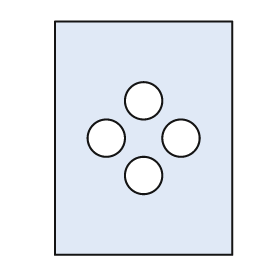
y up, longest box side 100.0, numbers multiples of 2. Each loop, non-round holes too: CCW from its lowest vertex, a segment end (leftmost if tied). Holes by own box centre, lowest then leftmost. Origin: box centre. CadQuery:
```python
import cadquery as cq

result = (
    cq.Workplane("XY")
    .moveTo(-38.0, -50.0)
    .lineTo(38.0, -50.0)
    .lineTo(38.0, 50.0)
    .lineTo(-38.0, 50.0)
    .close()
    .moveTo(0.0, -16.0)
    .circle(8.0)
    .moveTo(-16.0, 0.0)
    .circle(8.0)
    .moveTo(16.0, 0.0)
    .circle(8.0)
    .moveTo(0.0, 16.0)
    .circle(8.0)
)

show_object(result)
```